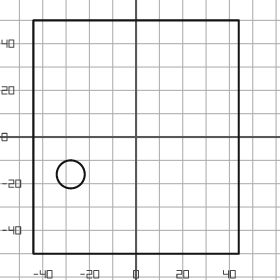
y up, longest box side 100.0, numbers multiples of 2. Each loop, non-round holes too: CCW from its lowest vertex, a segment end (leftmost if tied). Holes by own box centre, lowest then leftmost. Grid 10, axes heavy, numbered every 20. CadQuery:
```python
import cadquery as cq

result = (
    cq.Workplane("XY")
    .moveTo(-44.0, -50.0)
    .lineTo(44.0, -50.0)
    .lineTo(44.0, 50.0)
    .lineTo(-44.0, 50.0)
    .close()
    .moveTo(-28.0, -16.0)
    .circle(6.0)
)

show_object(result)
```